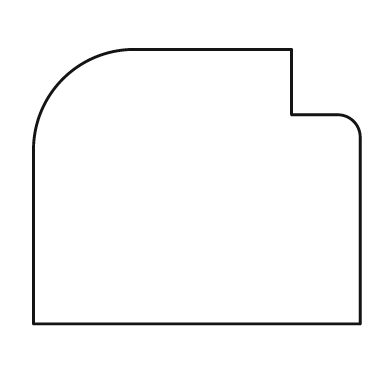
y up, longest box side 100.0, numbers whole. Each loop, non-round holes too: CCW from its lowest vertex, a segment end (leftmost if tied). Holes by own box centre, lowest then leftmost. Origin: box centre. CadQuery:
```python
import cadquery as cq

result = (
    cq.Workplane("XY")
    .moveTo(-50.0, -42.0)
    .lineTo(50.0, -42.0)
    .lineTo(50.0, 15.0)
    .threePointArc((48.0, 20.0), (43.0, 22.0))
    .lineTo(29.0, 22.0)
    .lineTo(29.0, 42.0)
    .lineTo(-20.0, 42.0)
    .threePointArc((-41.0, 33.0), (-50.0, 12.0))
    .close()
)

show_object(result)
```